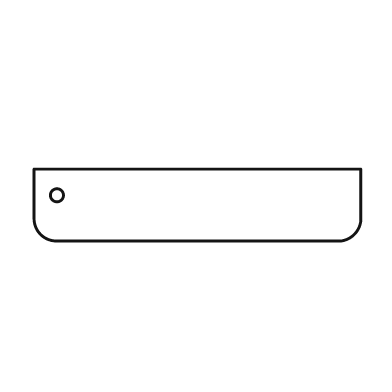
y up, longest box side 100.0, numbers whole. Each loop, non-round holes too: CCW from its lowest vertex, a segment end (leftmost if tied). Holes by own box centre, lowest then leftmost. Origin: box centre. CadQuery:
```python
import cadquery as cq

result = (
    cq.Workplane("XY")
    .moveTo(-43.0, -11.0)
    .lineTo(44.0, -11.0)
    .threePointArc((48.0, -9.0), (50.0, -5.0))
    .lineTo(50.0, 11.0)
    .lineTo(-50.0, 11.0)
    .lineTo(-50.0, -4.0)
    .threePointArc((-48.0, -9.0), (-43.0, -11.0))
    .close()
    .moveTo(-43.0, 3.0)
    .circle(2.0)
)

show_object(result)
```